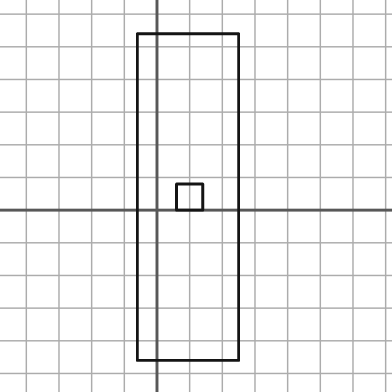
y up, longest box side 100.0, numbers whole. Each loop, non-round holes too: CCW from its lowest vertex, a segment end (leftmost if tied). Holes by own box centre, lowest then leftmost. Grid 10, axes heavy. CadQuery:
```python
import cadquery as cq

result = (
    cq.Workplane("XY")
    .moveTo(-6.0, -46.0)
    .lineTo(25.0, -46.0)
    .lineTo(25.0, 54.0)
    .lineTo(-6.0, 54.0)
    .close()
    .moveTo(6.0, 0.0)
    .lineTo(14.0, 0.0)
    .lineTo(14.0, 8.0)
    .lineTo(6.0, 8.0)
    .close()
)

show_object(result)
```